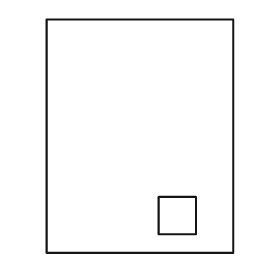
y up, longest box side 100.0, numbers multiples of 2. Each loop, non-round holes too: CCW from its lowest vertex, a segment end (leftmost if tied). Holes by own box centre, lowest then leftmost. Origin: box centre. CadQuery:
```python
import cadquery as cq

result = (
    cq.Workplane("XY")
    .moveTo(-40.0, -50.0)
    .lineTo(40.0, -50.0)
    .lineTo(40.0, 50.0)
    .lineTo(-40.0, 50.0)
    .close()
    .moveTo(8.0, -42.0)
    .lineTo(24.0, -42.0)
    .lineTo(24.0, -26.0)
    .lineTo(8.0, -26.0)
    .close()
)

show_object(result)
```